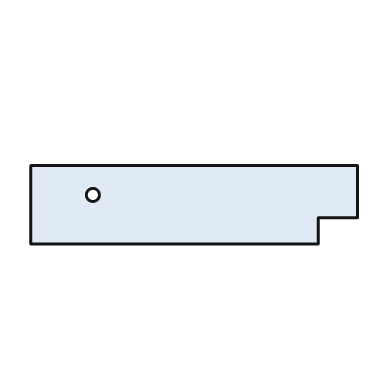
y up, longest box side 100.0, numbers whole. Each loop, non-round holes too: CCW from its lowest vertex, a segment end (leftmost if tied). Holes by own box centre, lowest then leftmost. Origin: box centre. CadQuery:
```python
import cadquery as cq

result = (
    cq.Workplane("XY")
    .moveTo(-50.0, -12.0)
    .lineTo(38.0, -12.0)
    .lineTo(38.0, -4.0)
    .lineTo(50.0, -4.0)
    .lineTo(50.0, 12.0)
    .lineTo(-50.0, 12.0)
    .close()
    .moveTo(-31.0, 3.0)
    .circle(2.0)
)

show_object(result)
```